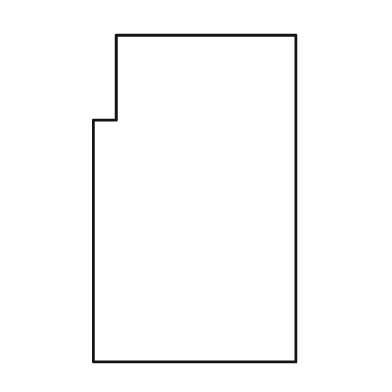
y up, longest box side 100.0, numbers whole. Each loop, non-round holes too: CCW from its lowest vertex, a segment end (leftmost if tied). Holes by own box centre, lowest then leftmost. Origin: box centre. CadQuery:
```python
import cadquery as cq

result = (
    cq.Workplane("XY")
    .moveTo(-31.0, -50.0)
    .lineTo(31.0, -50.0)
    .lineTo(31.0, 50.0)
    .lineTo(-24.0, 50.0)
    .lineTo(-24.0, 24.0)
    .lineTo(-31.0, 24.0)
    .close()
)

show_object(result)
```